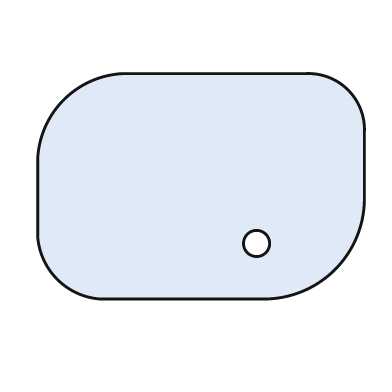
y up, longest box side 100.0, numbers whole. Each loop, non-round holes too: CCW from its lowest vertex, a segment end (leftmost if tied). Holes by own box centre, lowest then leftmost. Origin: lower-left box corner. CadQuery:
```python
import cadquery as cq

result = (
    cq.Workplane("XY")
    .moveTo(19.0, 0.0)
    .lineTo(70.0, 0.0)
    .threePointArc((91.0, 9.0), (100.0, 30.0))
    .lineTo(100.0, 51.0)
    .threePointArc((95.0, 64.0), (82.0, 69.0))
    .lineTo(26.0, 69.0)
    .threePointArc((8.0, 61.0), (0.0, 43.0))
    .lineTo(0.0, 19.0)
    .threePointArc((6.0, 6.0), (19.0, 0.0))
    .close()
    .moveTo(67.0, 17.0)
    .circle(4.0)
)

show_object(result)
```